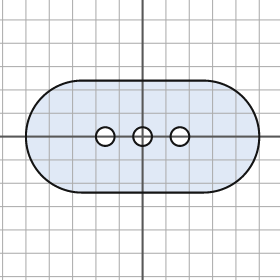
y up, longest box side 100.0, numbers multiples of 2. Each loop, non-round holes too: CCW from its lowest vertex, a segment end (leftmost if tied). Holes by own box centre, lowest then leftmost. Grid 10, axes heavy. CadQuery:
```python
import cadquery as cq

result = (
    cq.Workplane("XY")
    .moveTo(-26.0, -24.0)
    .lineTo(26.0, -24.0)
    .threePointArc((50.0, 0.0), (26.0, 24.0))
    .lineTo(-26.0, 24.0)
    .threePointArc((-50.0, 0.0), (-26.0, -24.0))
    .close()
    .moveTo(-16.0, 0.0)
    .circle(4.0)
    .moveTo(0.0, 0.0)
    .circle(4.0)
    .moveTo(16.0, 0.0)
    .circle(4.0)
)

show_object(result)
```